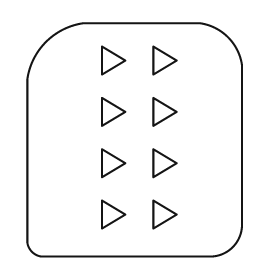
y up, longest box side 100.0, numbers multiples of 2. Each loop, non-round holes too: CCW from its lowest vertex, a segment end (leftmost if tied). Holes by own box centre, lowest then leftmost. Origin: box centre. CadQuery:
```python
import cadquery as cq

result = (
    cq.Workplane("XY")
    .moveTo(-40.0, -50.0)
    .lineTo(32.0, -50.0)
    .threePointArc((42.0, -46.0), (46.0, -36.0))
    .lineTo(46.0, 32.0)
    .threePointArc((40.0, 44.0), (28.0, 50.0))
    .lineTo(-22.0, 50.0)
    .threePointArc((-38.0, 42.0), (-46.0, 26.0))
    .lineTo(-46.0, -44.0)
    .threePointArc((-44.0, -48.0), (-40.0, -50.0))
    .close()
    .moveTo(-14.0, -38.0)
    .lineTo(-4.0, -32.0)
    .lineTo(-14.0, -26.0)
    .close()
    .moveTo(8.0, -38.0)
    .lineTo(18.0, -32.0)
    .lineTo(8.0, -26.0)
    .close()
    .moveTo(-14.0, -16.0)
    .lineTo(-4.0, -10.0)
    .lineTo(-14.0, -4.0)
    .close()
    .moveTo(8.0, -16.0)
    .lineTo(18.0, -10.0)
    .lineTo(8.0, -4.0)
    .close()
    .moveTo(-14.0, 6.0)
    .lineTo(-4.0, 12.0)
    .lineTo(-14.0, 18.0)
    .close()
    .moveTo(8.0, 6.0)
    .lineTo(18.0, 12.0)
    .lineTo(8.0, 18.0)
    .close()
    .moveTo(-14.0, 28.0)
    .lineTo(-4.0, 34.0)
    .lineTo(-14.0, 40.0)
    .close()
    .moveTo(8.0, 28.0)
    .lineTo(18.0, 34.0)
    .lineTo(8.0, 40.0)
    .close()
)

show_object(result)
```